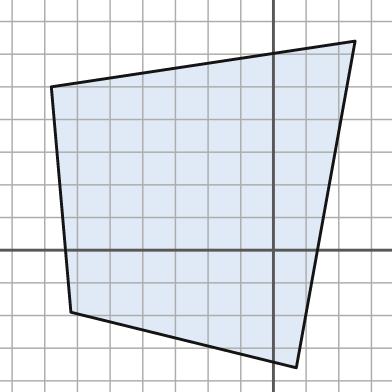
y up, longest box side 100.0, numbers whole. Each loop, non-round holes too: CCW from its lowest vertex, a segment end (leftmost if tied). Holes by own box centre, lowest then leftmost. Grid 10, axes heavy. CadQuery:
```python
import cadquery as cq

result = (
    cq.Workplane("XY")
    .moveTo(7.0, -36.0)
    .lineTo(25.0, 64.0)
    .lineTo(-68.0, 50.0)
    .lineTo(-62.0, -19.0)
    .close()
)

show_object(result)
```